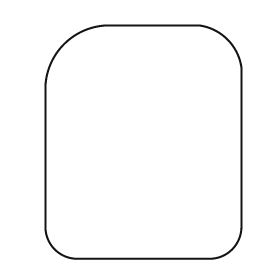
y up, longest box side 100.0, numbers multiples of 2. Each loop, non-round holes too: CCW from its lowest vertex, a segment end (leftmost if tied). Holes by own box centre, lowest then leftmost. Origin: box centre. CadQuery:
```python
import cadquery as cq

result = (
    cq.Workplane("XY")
    .moveTo(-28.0, -50.0)
    .lineTo(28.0, -50.0)
    .threePointArc((38.0, -46.0), (42.0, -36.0))
    .lineTo(42.0, 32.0)
    .threePointArc((36.0, 44.0), (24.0, 50.0))
    .lineTo(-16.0, 50.0)
    .threePointArc((-34.0, 42.0), (-42.0, 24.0))
    .lineTo(-42.0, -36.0)
    .threePointArc((-38.0, -46.0), (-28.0, -50.0))
    .close()
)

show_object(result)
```